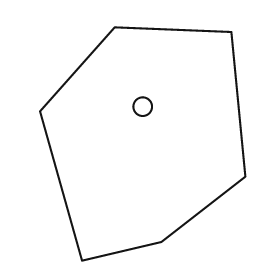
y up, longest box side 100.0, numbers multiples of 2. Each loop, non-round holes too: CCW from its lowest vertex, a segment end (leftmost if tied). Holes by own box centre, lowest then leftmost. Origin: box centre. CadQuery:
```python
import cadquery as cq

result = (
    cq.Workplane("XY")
    .moveTo(-26.0, -50.0)
    .lineTo(8.0, -42.0)
    .lineTo(44.0, -14.0)
    .lineTo(38.0, 48.0)
    .lineTo(-12.0, 50.0)
    .lineTo(-44.0, 14.0)
    .close()
    .moveTo(0.0, 16.0)
    .circle(4.0)
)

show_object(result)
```